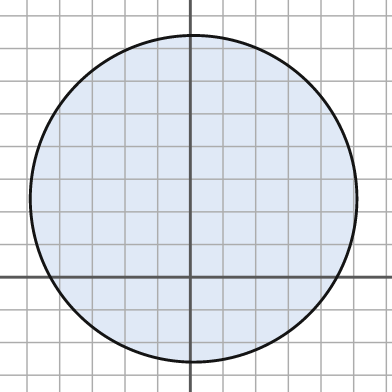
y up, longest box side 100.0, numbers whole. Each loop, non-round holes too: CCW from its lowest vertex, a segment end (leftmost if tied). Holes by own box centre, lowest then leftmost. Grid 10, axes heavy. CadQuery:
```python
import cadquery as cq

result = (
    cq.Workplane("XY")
    .moveTo(1.0, 24.0)
    .circle(50.0)
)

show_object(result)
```